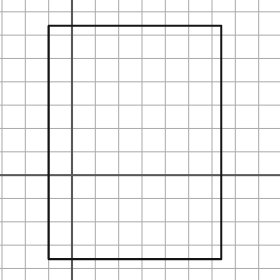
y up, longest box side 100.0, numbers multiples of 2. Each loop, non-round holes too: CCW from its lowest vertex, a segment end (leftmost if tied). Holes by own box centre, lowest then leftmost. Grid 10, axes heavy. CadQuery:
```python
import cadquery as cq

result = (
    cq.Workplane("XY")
    .moveTo(-10.0, -36.0)
    .lineTo(64.0, -36.0)
    .lineTo(64.0, 64.0)
    .lineTo(-10.0, 64.0)
    .close()
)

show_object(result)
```